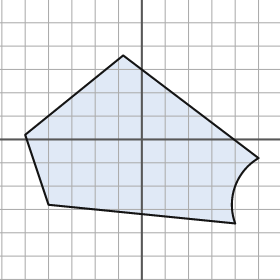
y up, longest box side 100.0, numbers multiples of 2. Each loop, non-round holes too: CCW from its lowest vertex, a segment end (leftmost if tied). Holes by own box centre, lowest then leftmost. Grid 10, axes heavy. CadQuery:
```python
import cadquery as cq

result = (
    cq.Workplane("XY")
    .moveTo(40.0, -36.0)
    .threePointArc((40.0, -20.0), (50.0, -8.0))
    .lineTo(-8.0, 36.0)
    .lineTo(-50.0, 2.0)
    .lineTo(-40.0, -28.0)
    .close()
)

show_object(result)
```